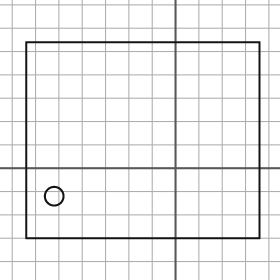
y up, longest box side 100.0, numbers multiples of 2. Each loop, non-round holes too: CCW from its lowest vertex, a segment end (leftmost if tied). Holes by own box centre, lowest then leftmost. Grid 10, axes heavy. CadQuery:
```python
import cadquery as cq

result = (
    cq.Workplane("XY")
    .moveTo(-64.0, -30.0)
    .lineTo(36.0, -30.0)
    .lineTo(36.0, 54.0)
    .lineTo(-64.0, 54.0)
    .close()
    .moveTo(-52.0, -12.0)
    .circle(4.0)
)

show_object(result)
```